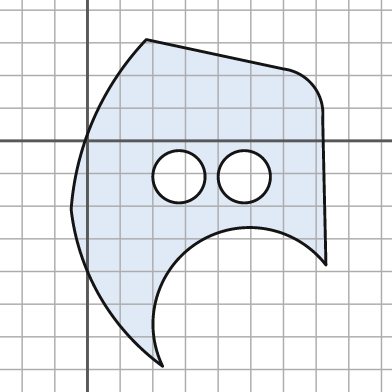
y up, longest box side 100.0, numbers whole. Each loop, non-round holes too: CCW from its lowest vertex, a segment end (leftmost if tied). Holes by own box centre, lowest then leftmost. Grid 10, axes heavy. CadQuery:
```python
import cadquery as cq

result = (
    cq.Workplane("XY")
    .moveTo(23.0, -69.0)
    .threePointArc((34.0, -31.0), (73.0, -38.0))
    .lineTo(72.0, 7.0)
    .threePointArc((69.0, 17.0), (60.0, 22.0))
    .lineTo(18.0, 31.0)
    .threePointArc((2.0, 7.0), (-5.0, -21.0))
    .threePointArc((4.0, -48.0), (23.0, -69.0))
    .close()
    .moveTo(28.0, -11.0)
    .circle(8.0)
    .moveTo(48.0, -11.0)
    .circle(8.0)
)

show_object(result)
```